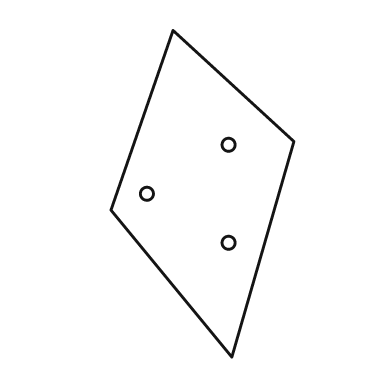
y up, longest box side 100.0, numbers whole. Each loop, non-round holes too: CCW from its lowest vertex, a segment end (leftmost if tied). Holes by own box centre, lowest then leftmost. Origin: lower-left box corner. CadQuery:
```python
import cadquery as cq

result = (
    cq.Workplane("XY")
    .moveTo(37.0, 0.0)
    .lineTo(56.0, 66.0)
    .lineTo(19.0, 100.0)
    .lineTo(0.0, 45.0)
    .close()
    .moveTo(36.0, 35.0)
    .circle(2.0)
    .moveTo(11.0, 50.0)
    .circle(2.0)
    .moveTo(36.0, 65.0)
    .circle(2.0)
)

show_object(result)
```